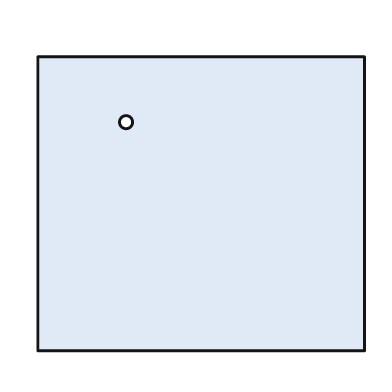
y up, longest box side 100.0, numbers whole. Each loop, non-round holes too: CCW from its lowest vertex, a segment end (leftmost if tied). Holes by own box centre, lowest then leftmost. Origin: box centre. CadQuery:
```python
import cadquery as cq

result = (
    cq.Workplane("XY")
    .moveTo(-50.0, -45.0)
    .lineTo(50.0, -45.0)
    .lineTo(50.0, 45.0)
    .lineTo(-50.0, 45.0)
    .close()
    .moveTo(-23.0, 25.0)
    .circle(2.0)
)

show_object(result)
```